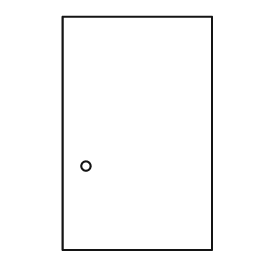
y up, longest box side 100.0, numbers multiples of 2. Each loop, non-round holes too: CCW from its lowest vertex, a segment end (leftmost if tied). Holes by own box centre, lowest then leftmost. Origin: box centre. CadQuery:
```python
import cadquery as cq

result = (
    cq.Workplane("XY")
    .moveTo(-32.0, -50.0)
    .lineTo(32.0, -50.0)
    .lineTo(32.0, 50.0)
    .lineTo(-32.0, 50.0)
    .close()
    .moveTo(-22.0, -14.0)
    .circle(2.0)
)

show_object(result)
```